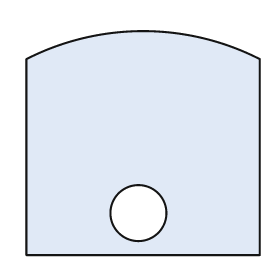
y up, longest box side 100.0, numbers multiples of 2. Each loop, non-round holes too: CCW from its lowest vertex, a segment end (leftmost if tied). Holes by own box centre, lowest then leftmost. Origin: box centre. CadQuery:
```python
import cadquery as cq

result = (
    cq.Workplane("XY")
    .moveTo(-50.0, -48.0)
    .lineTo(50.0, -48.0)
    .lineTo(50.0, 36.0)
    .threePointArc((0.0, 48.0), (-50.0, 36.0))
    .close()
    .moveTo(-2.0, -30.0)
    .circle(12.0)
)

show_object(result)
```